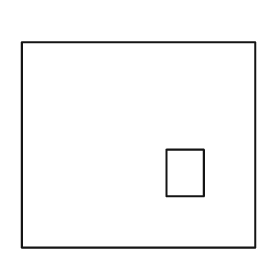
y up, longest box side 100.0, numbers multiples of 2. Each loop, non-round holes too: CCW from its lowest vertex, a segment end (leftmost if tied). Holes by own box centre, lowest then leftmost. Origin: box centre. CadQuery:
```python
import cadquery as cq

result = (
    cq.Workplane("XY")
    .moveTo(-50.0, -44.0)
    .lineTo(50.0, -44.0)
    .lineTo(50.0, 44.0)
    .lineTo(-50.0, 44.0)
    .close()
    .moveTo(12.0, -22.0)
    .lineTo(28.0, -22.0)
    .lineTo(28.0, -2.0)
    .lineTo(12.0, -2.0)
    .close()
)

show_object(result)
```